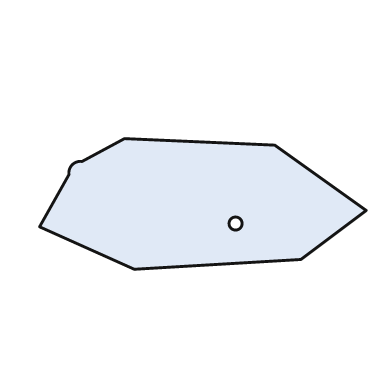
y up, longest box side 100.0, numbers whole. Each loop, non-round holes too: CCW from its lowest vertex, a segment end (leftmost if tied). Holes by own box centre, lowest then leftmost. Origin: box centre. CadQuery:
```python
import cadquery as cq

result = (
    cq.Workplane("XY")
    .moveTo(-21.0, -20.0)
    .lineTo(30.0, -17.0)
    .lineTo(50.0, -2.0)
    .lineTo(22.0, 18.0)
    .lineTo(-24.0, 20.0)
    .lineTo(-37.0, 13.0)
    .threePointArc((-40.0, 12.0), (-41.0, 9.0))
    .lineTo(-50.0, -7.0)
    .close()
    .moveTo(10.0, -6.0)
    .circle(2.0)
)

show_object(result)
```